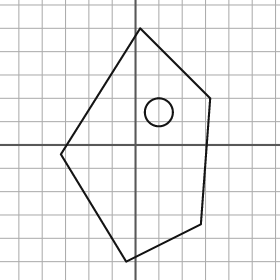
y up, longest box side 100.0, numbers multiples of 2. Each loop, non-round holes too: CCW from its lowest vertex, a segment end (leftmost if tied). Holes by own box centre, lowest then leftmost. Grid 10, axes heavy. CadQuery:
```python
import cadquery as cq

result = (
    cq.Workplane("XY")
    .moveTo(-4.0, -50.0)
    .lineTo(28.0, -34.0)
    .lineTo(32.0, 20.0)
    .lineTo(2.0, 50.0)
    .lineTo(-32.0, -4.0)
    .close()
    .moveTo(10.0, 14.0)
    .circle(6.0)
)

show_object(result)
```